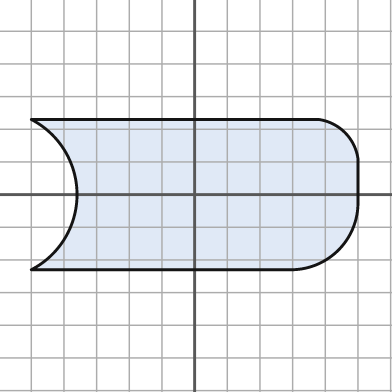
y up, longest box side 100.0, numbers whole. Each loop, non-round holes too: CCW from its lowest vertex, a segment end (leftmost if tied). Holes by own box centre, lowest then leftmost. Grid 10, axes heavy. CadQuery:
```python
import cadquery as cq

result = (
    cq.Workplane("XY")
    .moveTo(-50.0, -23.0)
    .lineTo(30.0, -23.0)
    .threePointArc((44.0, -17.0), (50.0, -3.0))
    .lineTo(50.0, 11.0)
    .threePointArc((46.0, 19.0), (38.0, 23.0))
    .lineTo(-50.0, 23.0)
    .threePointArc((-36.0, 0.0), (-50.0, -23.0))
    .close()
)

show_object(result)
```